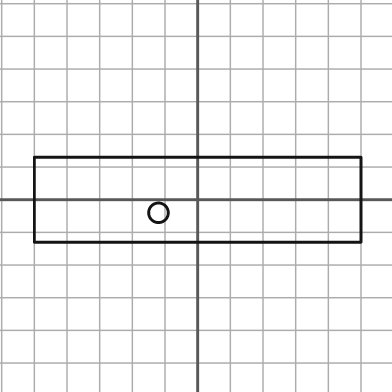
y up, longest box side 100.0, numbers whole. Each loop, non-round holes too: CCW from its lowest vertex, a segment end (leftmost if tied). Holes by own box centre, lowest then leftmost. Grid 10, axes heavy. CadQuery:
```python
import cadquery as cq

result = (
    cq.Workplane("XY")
    .moveTo(-50.0, -13.0)
    .lineTo(50.0, -13.0)
    .lineTo(50.0, 13.0)
    .lineTo(-50.0, 13.0)
    .close()
    .moveTo(-12.0, -4.0)
    .circle(3.0)
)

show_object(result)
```